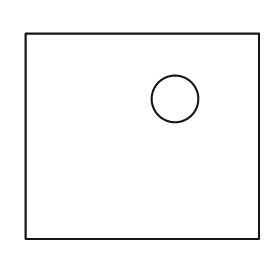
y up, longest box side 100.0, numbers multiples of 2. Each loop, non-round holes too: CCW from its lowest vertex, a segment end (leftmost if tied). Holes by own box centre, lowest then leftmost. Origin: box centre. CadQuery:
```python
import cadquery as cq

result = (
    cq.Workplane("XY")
    .moveTo(-50.0, -44.0)
    .lineTo(50.0, -44.0)
    .lineTo(50.0, 44.0)
    .lineTo(-50.0, 44.0)
    .close()
    .moveTo(14.0, 16.0)
    .circle(10.0)
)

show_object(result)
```